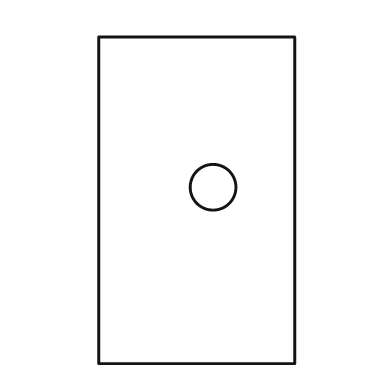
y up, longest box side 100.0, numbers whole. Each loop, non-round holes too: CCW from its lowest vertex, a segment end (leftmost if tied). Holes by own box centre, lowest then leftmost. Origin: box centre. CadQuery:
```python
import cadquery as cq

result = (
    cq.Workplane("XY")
    .moveTo(-30.0, -50.0)
    .lineTo(30.0, -50.0)
    .lineTo(30.0, 50.0)
    .lineTo(-30.0, 50.0)
    .close()
    .moveTo(5.0, 4.0)
    .circle(7.0)
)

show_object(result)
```